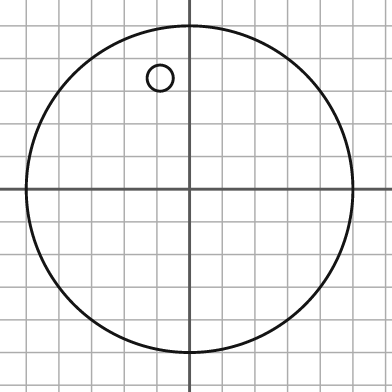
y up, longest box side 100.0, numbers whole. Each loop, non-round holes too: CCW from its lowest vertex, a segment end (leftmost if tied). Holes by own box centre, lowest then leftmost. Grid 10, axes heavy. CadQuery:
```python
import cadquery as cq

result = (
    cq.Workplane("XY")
    .moveTo(0.0, 0.0)
    .circle(50.0)
    .moveTo(-9.0, 34.0)
    .circle(4.0)
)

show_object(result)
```